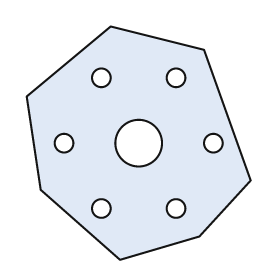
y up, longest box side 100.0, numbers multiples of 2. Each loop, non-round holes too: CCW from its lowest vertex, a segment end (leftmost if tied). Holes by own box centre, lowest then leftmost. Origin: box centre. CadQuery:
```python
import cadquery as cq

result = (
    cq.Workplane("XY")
    .moveTo(-8.0, -50.0)
    .lineTo(26.0, -40.0)
    .lineTo(48.0, -16.0)
    .lineTo(28.0, 40.0)
    .lineTo(-12.0, 50.0)
    .lineTo(-48.0, 20.0)
    .lineTo(-42.0, -20.0)
    .close()
    .moveTo(-16.0, -28.0)
    .circle(4.0)
    .moveTo(16.0, -28.0)
    .circle(4.0)
    .moveTo(-32.0, 0.0)
    .circle(4.0)
    .moveTo(0.0, 0.0)
    .circle(10.0)
    .moveTo(32.0, 0.0)
    .circle(4.0)
    .moveTo(-16.0, 28.0)
    .circle(4.0)
    .moveTo(16.0, 28.0)
    .circle(4.0)
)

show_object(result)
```